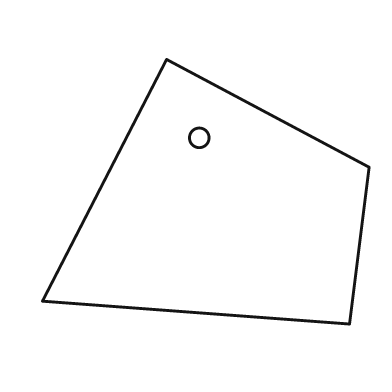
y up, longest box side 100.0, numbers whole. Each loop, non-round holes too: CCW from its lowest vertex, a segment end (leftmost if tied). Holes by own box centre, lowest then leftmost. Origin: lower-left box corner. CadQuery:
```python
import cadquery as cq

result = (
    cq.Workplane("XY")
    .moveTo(94.0, 0.0)
    .lineTo(100.0, 48.0)
    .lineTo(38.0, 81.0)
    .lineTo(0.0, 7.0)
    .close()
    .moveTo(48.0, 57.0)
    .circle(3.0)
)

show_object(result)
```